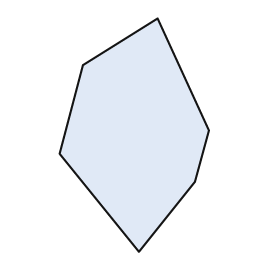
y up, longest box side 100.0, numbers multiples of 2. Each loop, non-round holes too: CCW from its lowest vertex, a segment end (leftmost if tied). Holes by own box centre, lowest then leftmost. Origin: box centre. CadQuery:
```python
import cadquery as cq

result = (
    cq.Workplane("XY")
    .moveTo(2.0, -50.0)
    .lineTo(26.0, -20.0)
    .lineTo(32.0, 2.0)
    .lineTo(10.0, 50.0)
    .lineTo(-22.0, 30.0)
    .lineTo(-32.0, -8.0)
    .close()
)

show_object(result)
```